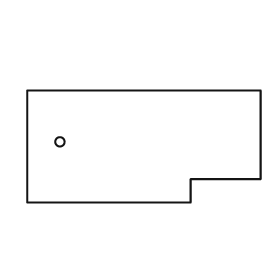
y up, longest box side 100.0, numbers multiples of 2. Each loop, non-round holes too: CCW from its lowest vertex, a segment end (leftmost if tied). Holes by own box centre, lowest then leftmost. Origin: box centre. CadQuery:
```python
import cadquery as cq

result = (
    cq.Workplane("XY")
    .moveTo(-50.0, -24.0)
    .lineTo(20.0, -24.0)
    .lineTo(20.0, -14.0)
    .lineTo(50.0, -14.0)
    .lineTo(50.0, 24.0)
    .lineTo(-50.0, 24.0)
    .close()
    .moveTo(-36.0, 2.0)
    .circle(2.0)
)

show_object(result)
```